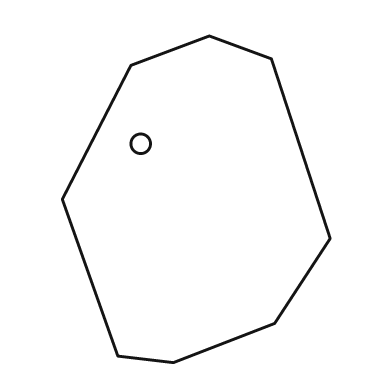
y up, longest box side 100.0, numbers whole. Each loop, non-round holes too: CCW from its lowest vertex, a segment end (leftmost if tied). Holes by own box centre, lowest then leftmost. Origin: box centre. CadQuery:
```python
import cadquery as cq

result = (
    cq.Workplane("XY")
    .moveTo(-7.0, -50.0)
    .lineTo(24.0, -38.0)
    .lineTo(41.0, -12.0)
    .lineTo(23.0, 43.0)
    .lineTo(4.0, 50.0)
    .lineTo(-20.0, 41.0)
    .lineTo(-41.0, 0.0)
    .lineTo(-24.0, -48.0)
    .close()
    .moveTo(-17.0, 17.0)
    .circle(3.0)
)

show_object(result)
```